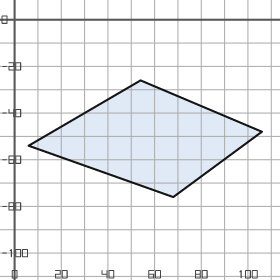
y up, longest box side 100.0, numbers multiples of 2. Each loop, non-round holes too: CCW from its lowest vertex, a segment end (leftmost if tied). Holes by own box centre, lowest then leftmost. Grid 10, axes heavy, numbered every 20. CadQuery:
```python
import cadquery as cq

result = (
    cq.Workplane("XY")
    .moveTo(68.0, -76.0)
    .lineTo(106.0, -48.0)
    .lineTo(54.0, -26.0)
    .lineTo(6.0, -54.0)
    .close()
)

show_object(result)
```